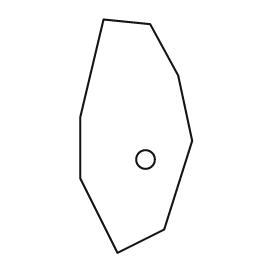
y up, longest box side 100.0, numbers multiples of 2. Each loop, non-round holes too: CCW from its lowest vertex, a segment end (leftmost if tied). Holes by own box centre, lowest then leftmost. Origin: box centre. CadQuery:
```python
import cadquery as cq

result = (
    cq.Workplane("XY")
    .moveTo(-8.0, -50.0)
    .lineTo(12.0, -40.0)
    .lineTo(24.0, -2.0)
    .lineTo(18.0, 26.0)
    .lineTo(6.0, 48.0)
    .lineTo(-14.0, 50.0)
    .lineTo(-24.0, 8.0)
    .lineTo(-24.0, -18.0)
    .close()
    .moveTo(4.0, -10.0)
    .circle(4.0)
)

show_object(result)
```